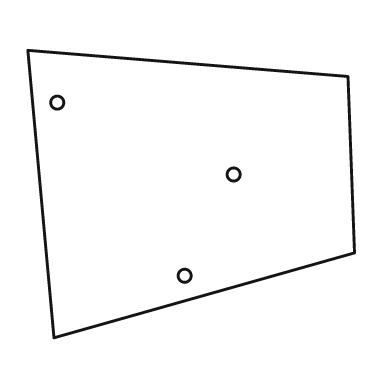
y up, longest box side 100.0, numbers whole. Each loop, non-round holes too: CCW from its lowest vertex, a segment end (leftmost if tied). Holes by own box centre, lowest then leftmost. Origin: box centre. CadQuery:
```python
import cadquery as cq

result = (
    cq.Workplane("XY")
    .moveTo(-42.0, -44.0)
    .lineTo(50.0, -18.0)
    .lineTo(48.0, 36.0)
    .lineTo(-50.0, 44.0)
    .close()
    .moveTo(-2.0, -25.0)
    .circle(2.0)
    .moveTo(13.0, 6.0)
    .circle(2.0)
    .moveTo(-41.0, 28.0)
    .circle(2.0)
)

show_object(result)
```